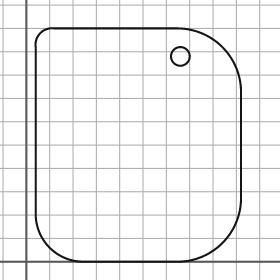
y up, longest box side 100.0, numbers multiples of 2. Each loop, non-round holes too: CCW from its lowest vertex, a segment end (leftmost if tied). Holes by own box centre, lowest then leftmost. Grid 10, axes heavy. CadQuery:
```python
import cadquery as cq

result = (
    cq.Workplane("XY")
    .moveTo(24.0, 0.0)
    .lineTo(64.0, 0.0)
    .threePointArc((84.0, 8.0), (92.0, 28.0))
    .lineTo(92.0, 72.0)
    .threePointArc((84.0, 92.0), (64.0, 100.0))
    .lineTo(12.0, 100.0)
    .threePointArc((6.0, 98.0), (4.0, 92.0))
    .lineTo(4.0, 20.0)
    .threePointArc((10.0, 6.0), (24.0, 0.0))
    .close()
    .moveTo(66.0, 88.0)
    .circle(4.0)
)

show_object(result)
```